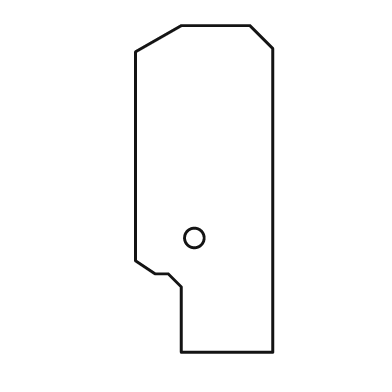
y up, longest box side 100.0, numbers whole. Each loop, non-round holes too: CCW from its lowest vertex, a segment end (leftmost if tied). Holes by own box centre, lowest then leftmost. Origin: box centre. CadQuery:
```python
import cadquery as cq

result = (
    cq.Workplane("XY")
    .moveTo(-7.0, -50.0)
    .lineTo(21.0, -50.0)
    .lineTo(21.0, 43.0)
    .lineTo(14.0, 50.0)
    .lineTo(-7.0, 50.0)
    .lineTo(-21.0, 42.0)
    .lineTo(-21.0, -22.0)
    .lineTo(-15.0, -26.0)
    .lineTo(-11.0, -26.0)
    .lineTo(-7.0, -30.0)
    .close()
    .moveTo(-3.0, -15.0)
    .circle(3.0)
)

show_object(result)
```